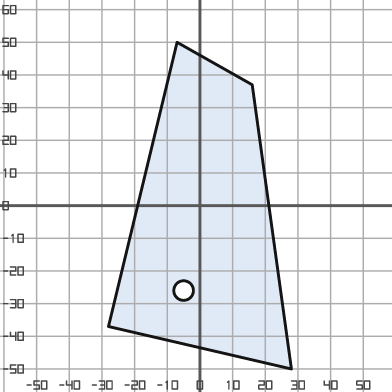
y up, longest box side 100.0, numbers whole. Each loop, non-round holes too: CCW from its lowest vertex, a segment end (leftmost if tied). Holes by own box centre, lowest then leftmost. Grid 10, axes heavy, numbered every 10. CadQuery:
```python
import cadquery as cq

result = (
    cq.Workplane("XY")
    .moveTo(28.0, -50.0)
    .lineTo(16.0, 37.0)
    .lineTo(-7.0, 50.0)
    .lineTo(-28.0, -37.0)
    .close()
    .moveTo(-5.0, -26.0)
    .circle(3.0)
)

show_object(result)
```